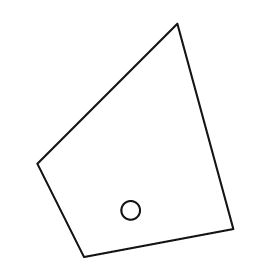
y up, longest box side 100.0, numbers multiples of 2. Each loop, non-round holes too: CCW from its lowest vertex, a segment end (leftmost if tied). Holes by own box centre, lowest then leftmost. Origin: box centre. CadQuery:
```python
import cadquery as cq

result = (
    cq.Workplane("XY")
    .moveTo(-22.0, -50.0)
    .lineTo(42.0, -38.0)
    .lineTo(18.0, 50.0)
    .lineTo(-42.0, -10.0)
    .close()
    .moveTo(-2.0, -30.0)
    .circle(4.0)
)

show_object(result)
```